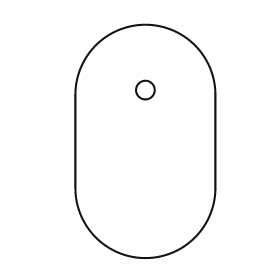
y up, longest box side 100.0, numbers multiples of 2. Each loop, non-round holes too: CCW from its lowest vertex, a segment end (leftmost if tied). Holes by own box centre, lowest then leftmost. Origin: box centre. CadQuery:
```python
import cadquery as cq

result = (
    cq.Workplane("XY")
    .moveTo(-30.0, -20.0)
    .threePointArc((0.0, -50.0), (30.0, -20.0))
    .lineTo(30.0, 20.0)
    .threePointArc((0.0, 50.0), (-30.0, 20.0))
    .close()
    .moveTo(0.0, 22.0)
    .circle(4.0)
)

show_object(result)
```